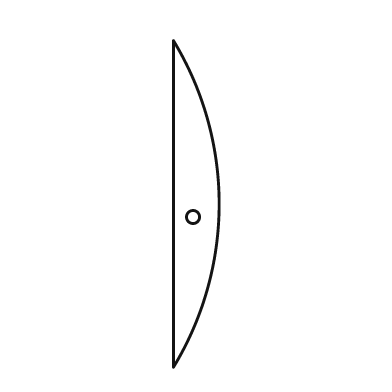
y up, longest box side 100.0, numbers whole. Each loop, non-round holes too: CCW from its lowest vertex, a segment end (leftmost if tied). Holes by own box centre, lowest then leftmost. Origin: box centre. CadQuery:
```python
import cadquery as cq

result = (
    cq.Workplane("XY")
    .moveTo(-7.0, -50.0)
    .threePointArc((7.0, 0.0), (-7.0, 50.0))
    .close()
    .moveTo(-1.0, -4.0)
    .circle(2.0)
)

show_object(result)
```